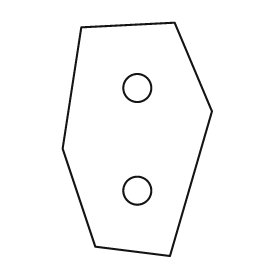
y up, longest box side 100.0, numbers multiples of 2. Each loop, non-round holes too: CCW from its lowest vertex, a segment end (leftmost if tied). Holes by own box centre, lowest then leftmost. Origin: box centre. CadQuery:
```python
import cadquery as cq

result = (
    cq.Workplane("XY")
    .moveTo(14.0, -50.0)
    .lineTo(32.0, 12.0)
    .lineTo(16.0, 50.0)
    .lineTo(-24.0, 48.0)
    .lineTo(-32.0, -4.0)
    .lineTo(-18.0, -46.0)
    .close()
    .moveTo(0.0, -22.0)
    .circle(6.0)
    .moveTo(0.0, 22.0)
    .circle(6.0)
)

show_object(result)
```